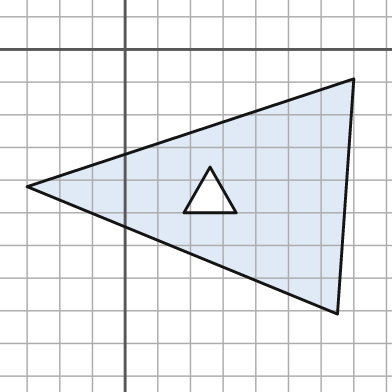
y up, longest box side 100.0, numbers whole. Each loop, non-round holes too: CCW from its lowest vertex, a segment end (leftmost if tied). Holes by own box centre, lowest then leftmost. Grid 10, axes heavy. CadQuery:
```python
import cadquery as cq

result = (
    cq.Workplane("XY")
    .moveTo(65.0, -81.0)
    .lineTo(70.0, -9.0)
    .lineTo(-30.0, -42.0)
    .close()
    .moveTo(18.0, -50.0)
    .lineTo(34.0, -50.0)
    .lineTo(26.0, -36.0)
    .close()
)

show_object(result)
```